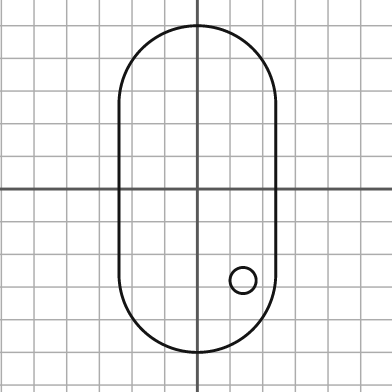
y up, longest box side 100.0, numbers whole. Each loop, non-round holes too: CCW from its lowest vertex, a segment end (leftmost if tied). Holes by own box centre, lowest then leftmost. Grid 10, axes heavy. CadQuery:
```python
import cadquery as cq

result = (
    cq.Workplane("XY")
    .moveTo(-24.0, -26.0)
    .threePointArc((0.0, -50.0), (24.0, -26.0))
    .lineTo(24.0, 26.0)
    .threePointArc((0.0, 50.0), (-24.0, 26.0))
    .close()
    .moveTo(14.0, -28.0)
    .circle(4.0)
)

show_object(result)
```